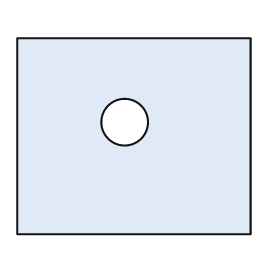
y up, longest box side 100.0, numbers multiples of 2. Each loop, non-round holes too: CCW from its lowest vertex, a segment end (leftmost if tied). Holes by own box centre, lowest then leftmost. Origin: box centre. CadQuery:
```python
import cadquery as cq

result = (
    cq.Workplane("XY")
    .moveTo(-50.0, -42.0)
    .lineTo(50.0, -42.0)
    .lineTo(50.0, 42.0)
    .lineTo(-50.0, 42.0)
    .close()
    .moveTo(-4.0, 6.0)
    .circle(10.0)
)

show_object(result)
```